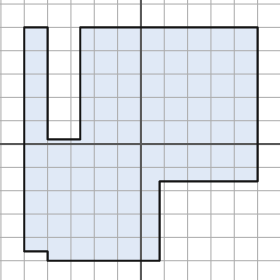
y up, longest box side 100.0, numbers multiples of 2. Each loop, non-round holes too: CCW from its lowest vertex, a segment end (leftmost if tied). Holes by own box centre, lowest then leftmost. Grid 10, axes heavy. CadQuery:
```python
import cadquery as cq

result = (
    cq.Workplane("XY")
    .moveTo(-40.0, -50.0)
    .lineTo(8.0, -50.0)
    .lineTo(8.0, -16.0)
    .lineTo(50.0, -16.0)
    .lineTo(50.0, 50.0)
    .lineTo(-26.0, 50.0)
    .lineTo(-26.0, 2.0)
    .lineTo(-40.0, 2.0)
    .lineTo(-40.0, 50.0)
    .lineTo(-50.0, 50.0)
    .lineTo(-50.0, -46.0)
    .lineTo(-40.0, -46.0)
    .close()
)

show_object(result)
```